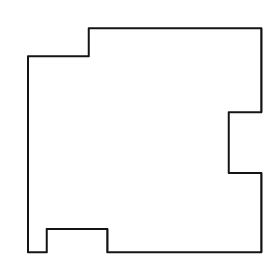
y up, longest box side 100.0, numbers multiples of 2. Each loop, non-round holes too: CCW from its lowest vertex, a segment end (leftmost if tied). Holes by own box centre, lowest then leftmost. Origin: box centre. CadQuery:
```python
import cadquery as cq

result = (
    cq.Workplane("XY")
    .moveTo(-50.0, -48.0)
    .lineTo(-42.0, -48.0)
    .lineTo(-42.0, -38.0)
    .lineTo(-16.0, -38.0)
    .lineTo(-16.0, -48.0)
    .lineTo(50.0, -48.0)
    .lineTo(50.0, -14.0)
    .lineTo(36.0, -14.0)
    .lineTo(36.0, 12.0)
    .lineTo(50.0, 12.0)
    .lineTo(50.0, 48.0)
    .lineTo(-24.0, 48.0)
    .lineTo(-24.0, 36.0)
    .lineTo(-50.0, 36.0)
    .close()
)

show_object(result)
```